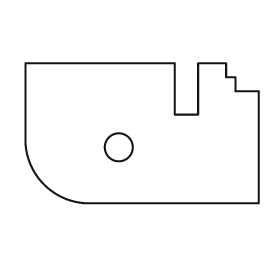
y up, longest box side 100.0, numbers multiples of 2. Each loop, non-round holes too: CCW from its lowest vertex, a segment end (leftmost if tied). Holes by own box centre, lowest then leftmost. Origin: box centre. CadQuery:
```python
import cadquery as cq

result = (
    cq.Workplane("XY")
    .moveTo(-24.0, -30.0)
    .lineTo(50.0, -30.0)
    .lineTo(50.0, 18.0)
    .lineTo(40.0, 18.0)
    .lineTo(40.0, 24.0)
    .lineTo(36.0, 24.0)
    .lineTo(36.0, 30.0)
    .lineTo(24.0, 30.0)
    .lineTo(24.0, 8.0)
    .lineTo(14.0, 8.0)
    .lineTo(14.0, 30.0)
    .lineTo(-50.0, 30.0)
    .lineTo(-50.0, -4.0)
    .threePointArc((-42.0, -22.0), (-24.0, -30.0))
    .close()
    .moveTo(-10.0, -6.0)
    .circle(6.0)
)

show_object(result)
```